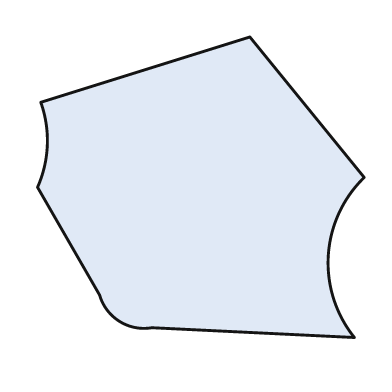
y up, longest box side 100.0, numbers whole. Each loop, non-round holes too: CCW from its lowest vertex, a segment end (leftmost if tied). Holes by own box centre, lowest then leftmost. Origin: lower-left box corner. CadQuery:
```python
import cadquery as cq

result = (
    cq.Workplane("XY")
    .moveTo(97.0, 0.0)
    .threePointArc((89.0, 25.0), (100.0, 49.0))
    .lineTo(65.0, 92.0)
    .lineTo(1.0, 72.0)
    .threePointArc((3.0, 59.0), (0.0, 46.0))
    .lineTo(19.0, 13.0)
    .threePointArc((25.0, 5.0), (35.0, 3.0))
    .close()
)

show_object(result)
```